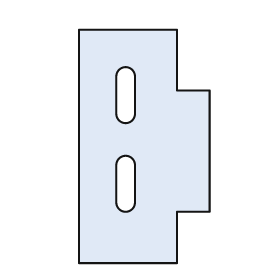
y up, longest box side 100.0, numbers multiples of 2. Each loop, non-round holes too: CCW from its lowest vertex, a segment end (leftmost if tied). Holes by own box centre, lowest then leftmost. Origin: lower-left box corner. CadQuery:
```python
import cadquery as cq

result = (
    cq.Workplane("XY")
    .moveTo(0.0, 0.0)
    .lineTo(42.0, 0.0)
    .lineTo(42.0, 22.0)
    .lineTo(56.0, 22.0)
    .lineTo(56.0, 74.0)
    .lineTo(42.0, 74.0)
    .lineTo(42.0, 100.0)
    .lineTo(0.0, 100.0)
    .close()
    .moveTo(16.0, 26.0)
    .threePointArc((20.0, 22.0), (24.0, 26.0))
    .lineTo(24.0, 42.0)
    .threePointArc((20.0, 46.0), (16.0, 42.0))
    .close()
    .moveTo(16.0, 64.0)
    .threePointArc((20.0, 60.0), (24.0, 64.0))
    .lineTo(24.0, 80.0)
    .threePointArc((20.0, 84.0), (16.0, 80.0))
    .close()
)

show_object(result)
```